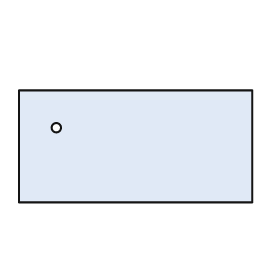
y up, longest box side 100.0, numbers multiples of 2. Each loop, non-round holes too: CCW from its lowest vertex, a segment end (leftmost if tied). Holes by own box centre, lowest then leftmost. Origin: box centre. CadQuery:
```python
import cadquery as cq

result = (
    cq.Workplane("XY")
    .moveTo(-50.0, -24.0)
    .lineTo(50.0, -24.0)
    .lineTo(50.0, 24.0)
    .lineTo(-50.0, 24.0)
    .close()
    .moveTo(-34.0, 8.0)
    .circle(2.0)
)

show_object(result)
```